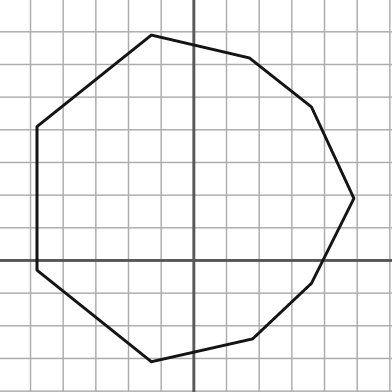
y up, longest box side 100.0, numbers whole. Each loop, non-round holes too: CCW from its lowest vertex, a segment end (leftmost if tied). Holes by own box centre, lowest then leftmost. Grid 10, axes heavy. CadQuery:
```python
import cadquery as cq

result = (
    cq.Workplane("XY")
    .moveTo(-13.0, -31.0)
    .lineTo(18.0, -24.0)
    .lineTo(36.0, -7.0)
    .lineTo(49.0, 19.0)
    .lineTo(36.0, 47.0)
    .lineTo(17.0, 62.0)
    .lineTo(-13.0, 69.0)
    .lineTo(-48.0, 41.0)
    .lineTo(-48.0, -3.0)
    .close()
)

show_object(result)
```